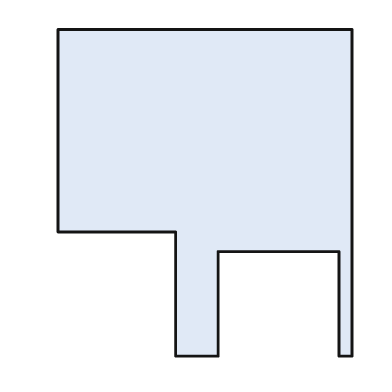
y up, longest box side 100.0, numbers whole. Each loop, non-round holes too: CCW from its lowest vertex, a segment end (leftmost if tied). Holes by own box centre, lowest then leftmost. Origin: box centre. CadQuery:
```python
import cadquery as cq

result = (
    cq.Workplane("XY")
    .moveTo(-9.0, -50.0)
    .lineTo(4.0, -50.0)
    .lineTo(4.0, -18.0)
    .lineTo(41.0, -18.0)
    .lineTo(41.0, -50.0)
    .lineTo(45.0, -50.0)
    .lineTo(45.0, 50.0)
    .lineTo(-45.0, 50.0)
    .lineTo(-45.0, -12.0)
    .lineTo(-9.0, -12.0)
    .close()
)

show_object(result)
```